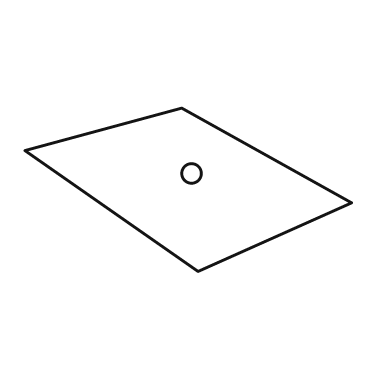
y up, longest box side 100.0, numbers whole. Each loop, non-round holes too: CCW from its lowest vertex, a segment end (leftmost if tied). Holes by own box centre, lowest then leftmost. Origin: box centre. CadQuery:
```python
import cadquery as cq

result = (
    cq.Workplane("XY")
    .moveTo(3.0, -25.0)
    .lineTo(50.0, -4.0)
    .lineTo(-2.0, 25.0)
    .lineTo(-50.0, 12.0)
    .close()
    .moveTo(1.0, 5.0)
    .circle(3.0)
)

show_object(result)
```